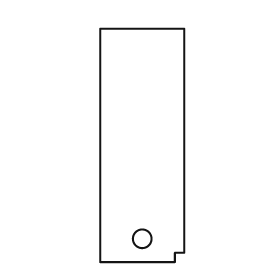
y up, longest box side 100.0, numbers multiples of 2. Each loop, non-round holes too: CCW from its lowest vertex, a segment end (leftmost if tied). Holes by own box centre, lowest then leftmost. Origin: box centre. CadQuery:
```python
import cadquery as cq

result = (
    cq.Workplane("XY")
    .moveTo(-18.0, -50.0)
    .lineTo(14.0, -50.0)
    .lineTo(14.0, -46.0)
    .lineTo(18.0, -46.0)
    .lineTo(18.0, 50.0)
    .lineTo(-18.0, 50.0)
    .close()
    .moveTo(0.0, -40.0)
    .circle(4.0)
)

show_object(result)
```